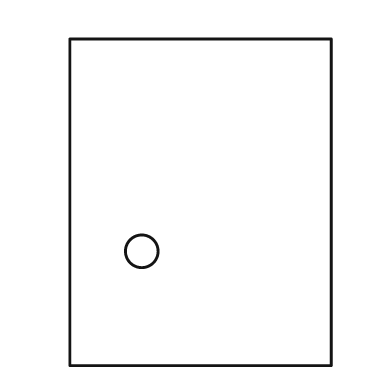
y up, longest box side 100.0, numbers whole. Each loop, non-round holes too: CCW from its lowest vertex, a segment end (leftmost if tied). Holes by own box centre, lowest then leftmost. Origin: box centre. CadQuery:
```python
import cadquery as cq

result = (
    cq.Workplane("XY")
    .moveTo(-40.0, -50.0)
    .lineTo(40.0, -50.0)
    .lineTo(40.0, 50.0)
    .lineTo(-40.0, 50.0)
    .close()
    .moveTo(-18.0, -15.0)
    .circle(5.0)
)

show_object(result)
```